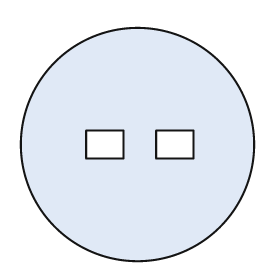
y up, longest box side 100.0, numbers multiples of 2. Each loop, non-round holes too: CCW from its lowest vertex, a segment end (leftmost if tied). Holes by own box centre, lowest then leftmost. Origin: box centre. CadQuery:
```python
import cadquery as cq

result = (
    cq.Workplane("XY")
    .moveTo(0.0, 0.0)
    .circle(50.0)
    .moveTo(-22.0, -6.0)
    .lineTo(-6.0, -6.0)
    .lineTo(-6.0, 6.0)
    .lineTo(-22.0, 6.0)
    .close()
    .moveTo(8.0, -6.0)
    .lineTo(24.0, -6.0)
    .lineTo(24.0, 6.0)
    .lineTo(8.0, 6.0)
    .close()
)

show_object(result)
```